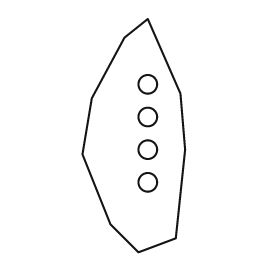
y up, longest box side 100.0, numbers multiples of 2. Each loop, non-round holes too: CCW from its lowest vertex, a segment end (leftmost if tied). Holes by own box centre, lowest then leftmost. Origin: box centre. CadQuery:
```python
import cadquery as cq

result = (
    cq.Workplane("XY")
    .moveTo(2.0, -50.0)
    .lineTo(18.0, -44.0)
    .lineTo(22.0, -6.0)
    .lineTo(20.0, 18.0)
    .lineTo(6.0, 50.0)
    .lineTo(-4.0, 42.0)
    .lineTo(-18.0, 16.0)
    .lineTo(-22.0, -8.0)
    .lineTo(-10.0, -38.0)
    .close()
    .moveTo(6.0, -20.0)
    .circle(4.0)
    .moveTo(6.0, -6.0)
    .circle(4.0)
    .moveTo(6.0, 8.0)
    .circle(4.0)
    .moveTo(6.0, 22.0)
    .circle(4.0)
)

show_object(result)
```